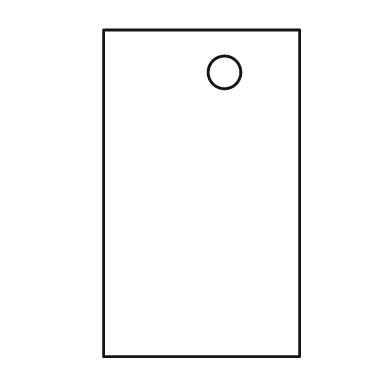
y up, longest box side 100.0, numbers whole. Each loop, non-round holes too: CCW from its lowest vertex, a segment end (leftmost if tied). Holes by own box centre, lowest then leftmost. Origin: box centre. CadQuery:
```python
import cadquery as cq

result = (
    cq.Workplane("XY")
    .moveTo(-30.0, -50.0)
    .lineTo(30.0, -50.0)
    .lineTo(30.0, 50.0)
    .lineTo(-30.0, 50.0)
    .close()
    .moveTo(7.0, 37.0)
    .circle(5.0)
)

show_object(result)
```